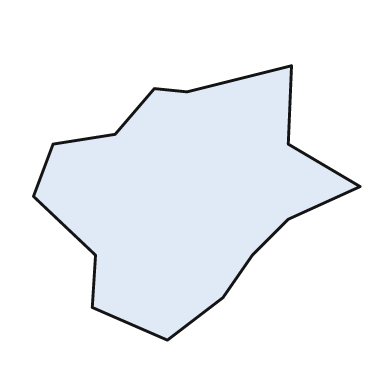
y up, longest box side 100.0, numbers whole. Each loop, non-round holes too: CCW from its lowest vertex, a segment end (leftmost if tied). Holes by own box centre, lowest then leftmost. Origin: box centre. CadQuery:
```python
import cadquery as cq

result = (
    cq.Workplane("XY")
    .moveTo(-9.0, -42.0)
    .lineTo(8.0, -29.0)
    .lineTo(17.0, -16.0)
    .lineTo(28.0, -5.0)
    .lineTo(50.0, 5.0)
    .lineTo(28.0, 18.0)
    .lineTo(29.0, 42.0)
    .lineTo(-3.0, 34.0)
    .lineTo(-13.0, 35.0)
    .lineTo(-25.0, 21.0)
    .lineTo(-44.0, 18.0)
    .lineTo(-50.0, 2.0)
    .lineTo(-31.0, -16.0)
    .lineTo(-32.0, -32.0)
    .close()
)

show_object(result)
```